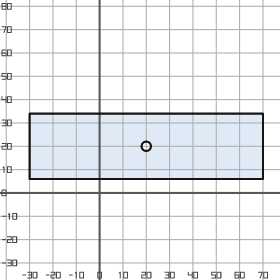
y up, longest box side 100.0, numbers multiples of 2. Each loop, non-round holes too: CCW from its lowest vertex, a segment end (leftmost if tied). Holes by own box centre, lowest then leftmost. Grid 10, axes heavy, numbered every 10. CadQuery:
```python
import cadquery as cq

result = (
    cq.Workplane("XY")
    .moveTo(-30.0, 6.0)
    .lineTo(70.0, 6.0)
    .lineTo(70.0, 34.0)
    .lineTo(-30.0, 34.0)
    .close()
    .moveTo(20.0, 20.0)
    .circle(2.0)
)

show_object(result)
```